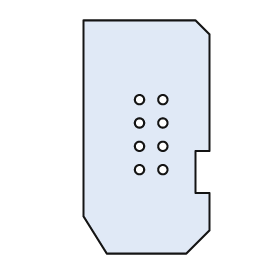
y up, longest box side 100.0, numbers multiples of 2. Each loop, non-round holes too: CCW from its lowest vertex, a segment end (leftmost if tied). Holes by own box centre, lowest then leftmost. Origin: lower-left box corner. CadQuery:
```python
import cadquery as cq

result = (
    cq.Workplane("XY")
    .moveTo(10.0, 0.0)
    .lineTo(44.0, 0.0)
    .lineTo(54.0, 10.0)
    .lineTo(54.0, 26.0)
    .lineTo(48.0, 26.0)
    .lineTo(48.0, 44.0)
    .lineTo(54.0, 44.0)
    .lineTo(54.0, 94.0)
    .lineTo(48.0, 100.0)
    .lineTo(0.0, 100.0)
    .lineTo(0.0, 16.0)
    .close()
    .moveTo(24.0, 36.0)
    .circle(2.0)
    .moveTo(34.0, 36.0)
    .circle(2.0)
    .moveTo(24.0, 46.0)
    .circle(2.0)
    .moveTo(34.0, 46.0)
    .circle(2.0)
    .moveTo(24.0, 56.0)
    .circle(2.0)
    .moveTo(34.0, 56.0)
    .circle(2.0)
    .moveTo(24.0, 66.0)
    .circle(2.0)
    .moveTo(34.0, 66.0)
    .circle(2.0)
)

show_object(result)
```